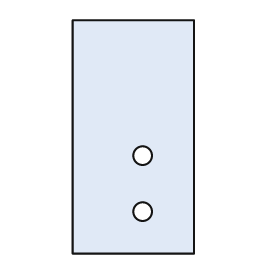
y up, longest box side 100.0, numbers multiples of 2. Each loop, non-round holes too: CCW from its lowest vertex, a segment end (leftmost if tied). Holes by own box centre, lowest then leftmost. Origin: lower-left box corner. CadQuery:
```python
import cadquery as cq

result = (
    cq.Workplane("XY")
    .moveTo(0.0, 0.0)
    .lineTo(52.0, 0.0)
    .lineTo(52.0, 100.0)
    .lineTo(0.0, 100.0)
    .close()
    .moveTo(30.0, 18.0)
    .circle(4.0)
    .moveTo(30.0, 42.0)
    .circle(4.0)
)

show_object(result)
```